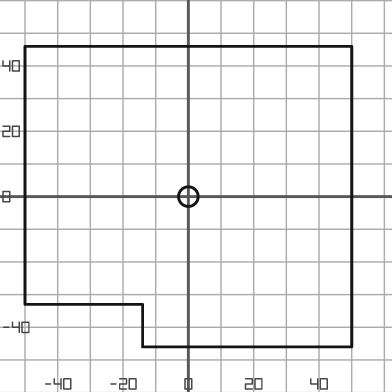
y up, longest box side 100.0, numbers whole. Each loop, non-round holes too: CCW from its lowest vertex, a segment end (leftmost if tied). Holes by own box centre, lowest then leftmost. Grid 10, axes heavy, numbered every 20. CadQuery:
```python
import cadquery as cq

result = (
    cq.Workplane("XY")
    .moveTo(-14.0, -46.0)
    .lineTo(50.0, -46.0)
    .lineTo(50.0, 46.0)
    .lineTo(-50.0, 46.0)
    .lineTo(-50.0, -33.0)
    .lineTo(-14.0, -33.0)
    .close()
    .moveTo(0.0, 0.0)
    .circle(3.0)
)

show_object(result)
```